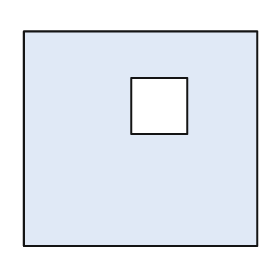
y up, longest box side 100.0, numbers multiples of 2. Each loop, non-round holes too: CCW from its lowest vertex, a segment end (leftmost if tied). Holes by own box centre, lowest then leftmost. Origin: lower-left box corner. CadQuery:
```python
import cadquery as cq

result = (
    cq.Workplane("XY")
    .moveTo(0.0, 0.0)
    .lineTo(100.0, 0.0)
    .lineTo(100.0, 92.0)
    .lineTo(0.0, 92.0)
    .close()
    .moveTo(46.0, 48.0)
    .lineTo(70.0, 48.0)
    .lineTo(70.0, 72.0)
    .lineTo(46.0, 72.0)
    .close()
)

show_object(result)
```